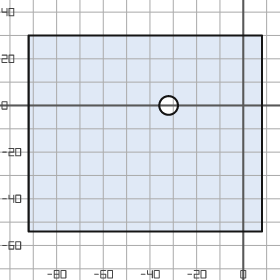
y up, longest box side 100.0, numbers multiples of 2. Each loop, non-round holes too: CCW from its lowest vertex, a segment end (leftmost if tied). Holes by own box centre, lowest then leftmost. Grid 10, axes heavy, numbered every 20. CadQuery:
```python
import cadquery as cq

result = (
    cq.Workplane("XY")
    .moveTo(-92.0, -54.0)
    .lineTo(8.0, -54.0)
    .lineTo(8.0, 30.0)
    .lineTo(-92.0, 30.0)
    .close()
    .moveTo(-32.0, 0.0)
    .circle(4.0)
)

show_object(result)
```